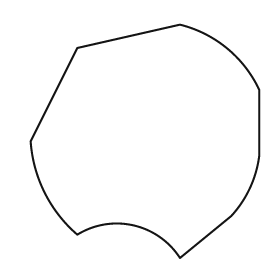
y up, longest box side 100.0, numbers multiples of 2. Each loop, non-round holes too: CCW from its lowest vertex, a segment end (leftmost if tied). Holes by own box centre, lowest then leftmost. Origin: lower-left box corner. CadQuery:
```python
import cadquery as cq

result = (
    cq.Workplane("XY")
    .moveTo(64.0, 0.0)
    .lineTo(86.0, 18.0)
    .threePointArc((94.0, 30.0), (98.0, 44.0))
    .lineTo(98.0, 72.0)
    .threePointArc((84.0, 90.0), (64.0, 100.0))
    .lineTo(20.0, 90.0)
    .lineTo(0.0, 50.0)
    .threePointArc((6.0, 28.0), (20.0, 10.0))
    .threePointArc((44.0, 14.0), (64.0, 0.0))
    .close()
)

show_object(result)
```